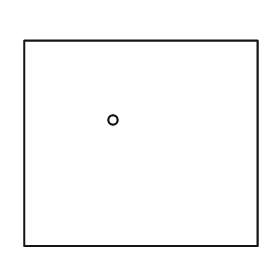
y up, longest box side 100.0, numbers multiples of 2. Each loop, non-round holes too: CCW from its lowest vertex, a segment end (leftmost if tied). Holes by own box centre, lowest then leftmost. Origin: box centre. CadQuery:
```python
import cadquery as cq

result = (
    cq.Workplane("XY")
    .moveTo(-50.0, -44.0)
    .lineTo(50.0, -44.0)
    .lineTo(50.0, 44.0)
    .lineTo(-50.0, 44.0)
    .close()
    .moveTo(-12.0, 10.0)
    .circle(2.0)
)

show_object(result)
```